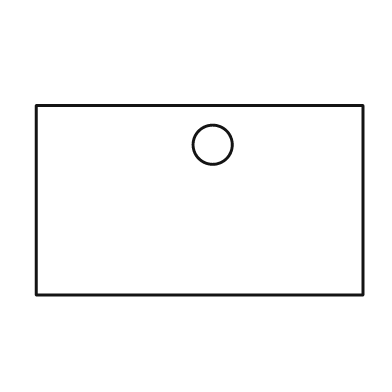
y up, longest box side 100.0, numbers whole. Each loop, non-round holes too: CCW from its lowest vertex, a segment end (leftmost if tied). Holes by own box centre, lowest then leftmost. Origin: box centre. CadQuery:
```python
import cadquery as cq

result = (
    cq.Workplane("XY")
    .moveTo(-50.0, -29.0)
    .lineTo(50.0, -29.0)
    .lineTo(50.0, 29.0)
    .lineTo(-50.0, 29.0)
    .close()
    .moveTo(4.0, 17.0)
    .circle(6.0)
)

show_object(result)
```